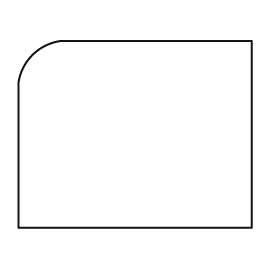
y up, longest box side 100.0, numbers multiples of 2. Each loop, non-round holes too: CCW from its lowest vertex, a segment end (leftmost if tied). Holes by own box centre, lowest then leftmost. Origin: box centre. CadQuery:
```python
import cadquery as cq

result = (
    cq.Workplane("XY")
    .moveTo(-50.0, -40.0)
    .lineTo(50.0, -40.0)
    .lineTo(50.0, 40.0)
    .lineTo(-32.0, 40.0)
    .threePointArc((-44.0, 34.0), (-50.0, 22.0))
    .close()
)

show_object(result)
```